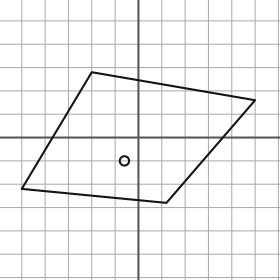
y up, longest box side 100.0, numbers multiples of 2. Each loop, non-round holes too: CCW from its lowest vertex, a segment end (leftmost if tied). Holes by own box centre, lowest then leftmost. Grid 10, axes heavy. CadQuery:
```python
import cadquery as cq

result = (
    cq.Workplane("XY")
    .moveTo(12.0, -28.0)
    .lineTo(50.0, 16.0)
    .lineTo(-20.0, 28.0)
    .lineTo(-50.0, -22.0)
    .close()
    .moveTo(-6.0, -10.0)
    .circle(2.0)
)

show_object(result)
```